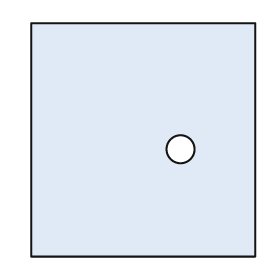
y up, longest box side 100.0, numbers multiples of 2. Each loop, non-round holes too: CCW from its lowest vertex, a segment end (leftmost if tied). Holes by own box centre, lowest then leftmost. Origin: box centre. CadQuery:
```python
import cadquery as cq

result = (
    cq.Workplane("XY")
    .moveTo(-48.0, -50.0)
    .lineTo(48.0, -50.0)
    .lineTo(48.0, 50.0)
    .lineTo(-48.0, 50.0)
    .close()
    .moveTo(16.0, -4.0)
    .circle(6.0)
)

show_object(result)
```